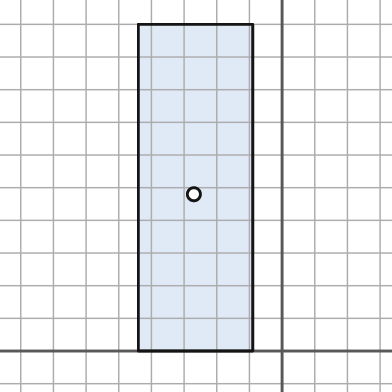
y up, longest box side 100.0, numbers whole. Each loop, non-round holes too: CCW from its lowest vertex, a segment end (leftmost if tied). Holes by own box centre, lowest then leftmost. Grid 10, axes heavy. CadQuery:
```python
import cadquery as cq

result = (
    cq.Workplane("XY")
    .moveTo(-44.0, 0.0)
    .lineTo(-9.0, 0.0)
    .lineTo(-9.0, 100.0)
    .lineTo(-44.0, 100.0)
    .close()
    .moveTo(-27.0, 48.0)
    .circle(2.0)
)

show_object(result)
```